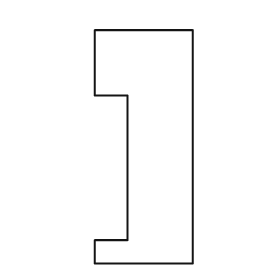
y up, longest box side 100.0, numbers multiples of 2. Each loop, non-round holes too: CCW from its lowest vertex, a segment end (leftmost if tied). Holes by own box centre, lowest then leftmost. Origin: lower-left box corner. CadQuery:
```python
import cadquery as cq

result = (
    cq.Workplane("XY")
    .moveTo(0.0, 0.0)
    .lineTo(42.0, 0.0)
    .lineTo(42.0, 100.0)
    .lineTo(0.0, 100.0)
    .lineTo(0.0, 72.0)
    .lineTo(14.0, 72.0)
    .lineTo(14.0, 10.0)
    .lineTo(0.0, 10.0)
    .close()
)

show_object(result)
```